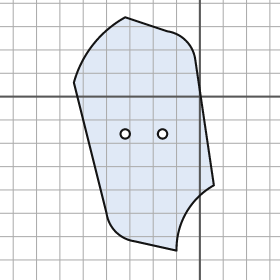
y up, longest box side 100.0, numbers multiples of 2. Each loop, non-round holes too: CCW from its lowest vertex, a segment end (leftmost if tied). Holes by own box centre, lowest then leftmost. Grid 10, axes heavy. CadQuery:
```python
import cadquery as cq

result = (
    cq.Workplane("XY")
    .moveTo(-10.0, -66.0)
    .threePointArc((-6.0, -50.0), (6.0, -38.0))
    .lineTo(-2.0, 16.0)
    .threePointArc((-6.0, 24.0), (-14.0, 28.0))
    .lineTo(-32.0, 34.0)
    .threePointArc((-46.0, 22.0), (-54.0, 6.0))
    .lineTo(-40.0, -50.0)
    .threePointArc((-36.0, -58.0), (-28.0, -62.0))
    .close()
    .moveTo(-32.0, -16.0)
    .circle(2.0)
    .moveTo(-16.0, -16.0)
    .circle(2.0)
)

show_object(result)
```